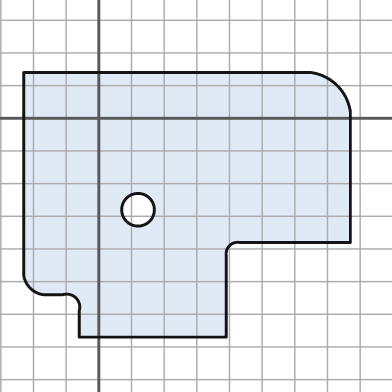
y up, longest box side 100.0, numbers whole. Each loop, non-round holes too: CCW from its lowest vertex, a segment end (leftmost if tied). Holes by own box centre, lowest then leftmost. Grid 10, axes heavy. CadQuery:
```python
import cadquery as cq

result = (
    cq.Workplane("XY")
    .moveTo(-6.0, -67.0)
    .lineTo(39.0, -67.0)
    .lineTo(39.0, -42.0)
    .threePointArc((40.0, -39.0), (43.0, -38.0))
    .lineTo(77.0, -38.0)
    .lineTo(77.0, 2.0)
    .threePointArc((73.0, 10.0), (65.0, 14.0))
    .lineTo(-23.0, 14.0)
    .lineTo(-23.0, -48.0)
    .threePointArc((-21.0, -52.0), (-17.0, -54.0))
    .lineTo(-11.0, -54.0)
    .threePointArc((-7.0, -55.0), (-6.0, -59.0))
    .close()
    .moveTo(12.0, -28.0)
    .circle(5.0)
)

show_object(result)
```